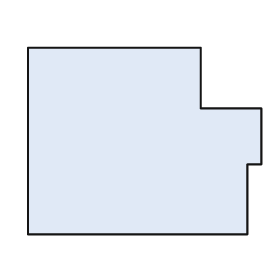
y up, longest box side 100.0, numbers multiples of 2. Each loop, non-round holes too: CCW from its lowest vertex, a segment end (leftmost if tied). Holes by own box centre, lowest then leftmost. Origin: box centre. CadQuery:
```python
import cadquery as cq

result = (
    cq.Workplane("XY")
    .moveTo(-50.0, -40.0)
    .lineTo(44.0, -40.0)
    .lineTo(44.0, -10.0)
    .lineTo(50.0, -10.0)
    .lineTo(50.0, 14.0)
    .lineTo(24.0, 14.0)
    .lineTo(24.0, 40.0)
    .lineTo(-50.0, 40.0)
    .close()
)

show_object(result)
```